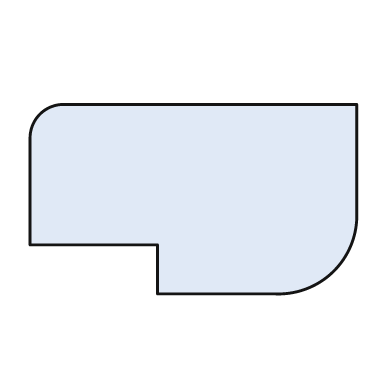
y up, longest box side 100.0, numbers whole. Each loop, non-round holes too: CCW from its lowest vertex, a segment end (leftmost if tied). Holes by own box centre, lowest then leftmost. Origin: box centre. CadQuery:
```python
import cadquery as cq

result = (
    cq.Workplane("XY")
    .moveTo(-11.0, -29.0)
    .lineTo(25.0, -29.0)
    .threePointArc((43.0, -22.0), (50.0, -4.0))
    .lineTo(50.0, 29.0)
    .lineTo(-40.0, 29.0)
    .threePointArc((-47.0, 26.0), (-50.0, 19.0))
    .lineTo(-50.0, -14.0)
    .lineTo(-11.0, -14.0)
    .close()
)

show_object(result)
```